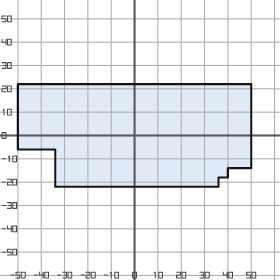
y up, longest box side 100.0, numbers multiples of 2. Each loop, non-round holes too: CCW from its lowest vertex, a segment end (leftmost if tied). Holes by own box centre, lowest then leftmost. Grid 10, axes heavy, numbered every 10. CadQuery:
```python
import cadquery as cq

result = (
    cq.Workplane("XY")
    .moveTo(-34.0, -22.0)
    .lineTo(36.0, -22.0)
    .lineTo(36.0, -18.0)
    .lineTo(40.0, -18.0)
    .lineTo(40.0, -14.0)
    .lineTo(50.0, -14.0)
    .lineTo(50.0, 22.0)
    .lineTo(-50.0, 22.0)
    .lineTo(-50.0, -6.0)
    .lineTo(-34.0, -6.0)
    .close()
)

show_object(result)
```